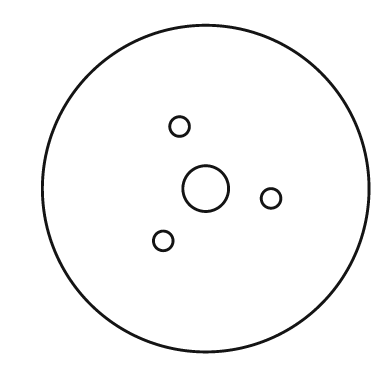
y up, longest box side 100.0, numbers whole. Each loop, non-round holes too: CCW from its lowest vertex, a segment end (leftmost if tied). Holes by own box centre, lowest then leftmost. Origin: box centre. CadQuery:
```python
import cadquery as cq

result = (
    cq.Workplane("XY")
    .moveTo(0.0, 0.0)
    .circle(50.0)
    .moveTo(-13.0, -16.0)
    .circle(3.0)
    .moveTo(20.0, -3.0)
    .circle(3.0)
    .moveTo(0.0, 0.0)
    .circle(7.0)
    .moveTo(-8.0, 19.0)
    .circle(3.0)
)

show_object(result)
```